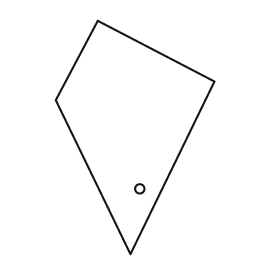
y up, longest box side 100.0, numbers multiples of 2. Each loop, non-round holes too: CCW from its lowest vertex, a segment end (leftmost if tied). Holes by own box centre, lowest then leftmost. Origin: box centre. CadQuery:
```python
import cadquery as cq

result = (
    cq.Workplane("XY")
    .moveTo(-2.0, -50.0)
    .lineTo(34.0, 24.0)
    .lineTo(-16.0, 50.0)
    .lineTo(-34.0, 16.0)
    .close()
    .moveTo(2.0, -22.0)
    .circle(2.0)
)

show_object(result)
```